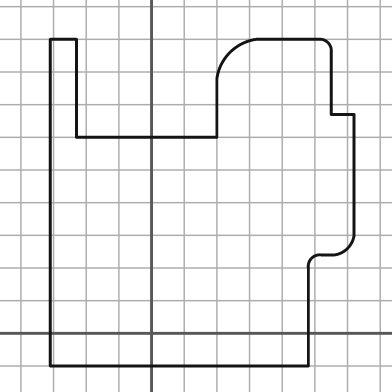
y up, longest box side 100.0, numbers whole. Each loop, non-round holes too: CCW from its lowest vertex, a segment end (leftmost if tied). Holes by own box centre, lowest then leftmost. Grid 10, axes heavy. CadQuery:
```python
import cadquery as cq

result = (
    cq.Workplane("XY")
    .moveTo(-31.0, -10.0)
    .lineTo(48.0, -10.0)
    .lineTo(48.0, 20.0)
    .threePointArc((49.0, 23.0), (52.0, 24.0))
    .lineTo(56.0, 24.0)
    .threePointArc((60.0, 26.0), (62.0, 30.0))
    .lineTo(62.0, 67.0)
    .lineTo(55.0, 67.0)
    .lineTo(55.0, 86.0)
    .threePointArc((54.0, 89.0), (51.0, 90.0))
    .lineTo(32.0, 90.0)
    .threePointArc((24.0, 86.0), (20.0, 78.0))
    .lineTo(20.0, 60.0)
    .lineTo(-23.0, 60.0)
    .lineTo(-23.0, 90.0)
    .lineTo(-31.0, 90.0)
    .close()
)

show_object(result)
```